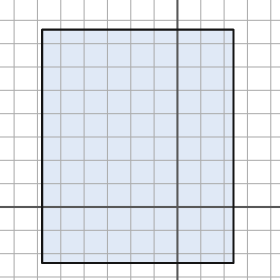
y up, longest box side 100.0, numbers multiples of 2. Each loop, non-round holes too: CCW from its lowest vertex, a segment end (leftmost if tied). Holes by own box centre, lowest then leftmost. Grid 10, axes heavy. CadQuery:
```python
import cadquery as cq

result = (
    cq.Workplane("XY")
    .moveTo(-58.0, -24.0)
    .lineTo(24.0, -24.0)
    .lineTo(24.0, 76.0)
    .lineTo(-58.0, 76.0)
    .close()
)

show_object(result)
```